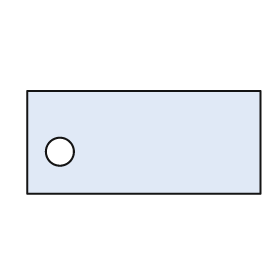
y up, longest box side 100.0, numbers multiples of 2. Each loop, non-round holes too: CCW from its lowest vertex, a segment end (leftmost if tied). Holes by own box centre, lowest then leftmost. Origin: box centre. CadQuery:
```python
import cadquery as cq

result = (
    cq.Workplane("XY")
    .moveTo(-50.0, -22.0)
    .lineTo(50.0, -22.0)
    .lineTo(50.0, 22.0)
    .lineTo(-50.0, 22.0)
    .close()
    .moveTo(-36.0, -4.0)
    .circle(6.0)
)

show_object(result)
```